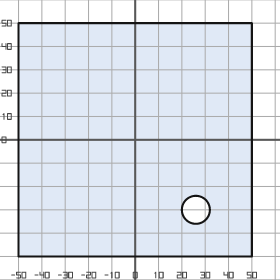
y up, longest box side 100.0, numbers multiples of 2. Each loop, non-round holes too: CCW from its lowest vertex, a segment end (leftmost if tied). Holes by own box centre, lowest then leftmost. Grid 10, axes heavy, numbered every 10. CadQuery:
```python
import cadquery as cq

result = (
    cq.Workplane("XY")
    .moveTo(-50.0, -50.0)
    .lineTo(50.0, -50.0)
    .lineTo(50.0, 50.0)
    .lineTo(-50.0, 50.0)
    .close()
    .moveTo(26.0, -30.0)
    .circle(6.0)
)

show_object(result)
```